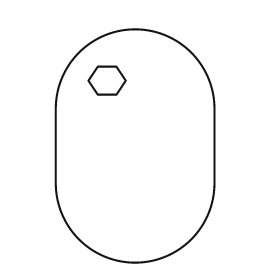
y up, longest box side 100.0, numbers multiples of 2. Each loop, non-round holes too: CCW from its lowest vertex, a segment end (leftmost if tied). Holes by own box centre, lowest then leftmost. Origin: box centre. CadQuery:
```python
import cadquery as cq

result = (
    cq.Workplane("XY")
    .moveTo(-34.0, -16.0)
    .threePointArc((0.0, -50.0), (34.0, -16.0))
    .lineTo(34.0, 16.0)
    .threePointArc((0.0, 50.0), (-34.0, 16.0))
    .close()
    .moveTo(-16.0, 22.0)
    .lineTo(-8.0, 22.0)
    .lineTo(-4.0, 28.0)
    .lineTo(-8.0, 34.0)
    .lineTo(-16.0, 34.0)
    .lineTo(-20.0, 28.0)
    .close()
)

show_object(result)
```